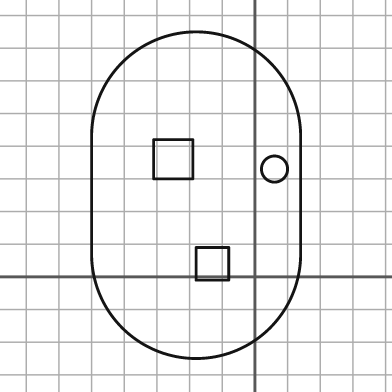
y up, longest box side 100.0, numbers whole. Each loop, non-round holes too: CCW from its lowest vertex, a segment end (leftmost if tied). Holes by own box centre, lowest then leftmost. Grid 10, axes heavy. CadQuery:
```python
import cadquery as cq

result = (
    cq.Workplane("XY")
    .moveTo(-50.0, 7.0)
    .threePointArc((-18.0, -25.0), (14.0, 7.0))
    .lineTo(14.0, 43.0)
    .threePointArc((-18.0, 75.0), (-50.0, 43.0))
    .close()
    .moveTo(-18.0, -1.0)
    .lineTo(-8.0, -1.0)
    .lineTo(-8.0, 9.0)
    .lineTo(-18.0, 9.0)
    .close()
    .moveTo(6.0, 33.0)
    .circle(4.0)
    .moveTo(-31.0, 30.0)
    .lineTo(-19.0, 30.0)
    .lineTo(-19.0, 42.0)
    .lineTo(-31.0, 42.0)
    .close()
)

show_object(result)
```